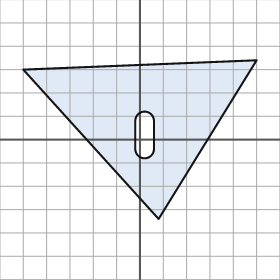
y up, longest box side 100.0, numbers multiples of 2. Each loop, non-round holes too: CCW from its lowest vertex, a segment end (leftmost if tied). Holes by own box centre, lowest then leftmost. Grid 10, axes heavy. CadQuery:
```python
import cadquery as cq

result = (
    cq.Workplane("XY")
    .moveTo(8.0, -34.0)
    .lineTo(50.0, 34.0)
    .lineTo(-50.0, 30.0)
    .close()
    .moveTo(-2.0, -4.0)
    .threePointArc((2.0, -8.0), (6.0, -4.0))
    .lineTo(6.0, 8.0)
    .threePointArc((2.0, 12.0), (-2.0, 8.0))
    .close()
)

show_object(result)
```